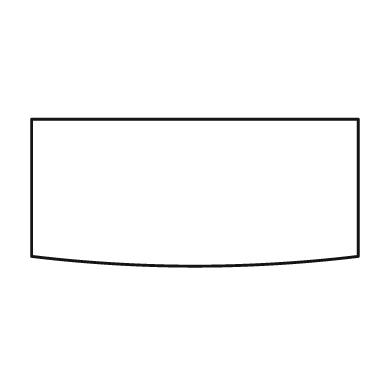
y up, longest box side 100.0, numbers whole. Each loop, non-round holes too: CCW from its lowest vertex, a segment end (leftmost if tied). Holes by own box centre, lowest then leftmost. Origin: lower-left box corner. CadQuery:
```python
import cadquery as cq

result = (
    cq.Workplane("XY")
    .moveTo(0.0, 3.0)
    .threePointArc((50.0, 0.0), (100.0, 3.0))
    .lineTo(100.0, 45.0)
    .lineTo(0.0, 45.0)
    .close()
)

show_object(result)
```